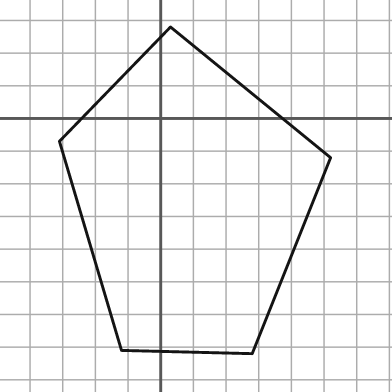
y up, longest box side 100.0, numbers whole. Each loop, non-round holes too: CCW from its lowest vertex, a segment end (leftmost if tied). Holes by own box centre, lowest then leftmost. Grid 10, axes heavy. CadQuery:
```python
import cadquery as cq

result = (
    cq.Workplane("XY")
    .moveTo(28.0, -72.0)
    .lineTo(52.0, -12.0)
    .lineTo(3.0, 28.0)
    .lineTo(-31.0, -7.0)
    .lineTo(-12.0, -71.0)
    .close()
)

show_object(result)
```